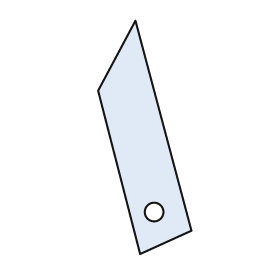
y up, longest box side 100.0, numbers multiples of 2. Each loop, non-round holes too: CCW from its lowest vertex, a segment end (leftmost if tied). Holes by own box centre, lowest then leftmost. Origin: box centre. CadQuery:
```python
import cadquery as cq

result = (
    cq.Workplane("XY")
    .moveTo(-2.0, -50.0)
    .lineTo(20.0, -40.0)
    .lineTo(-4.0, 50.0)
    .lineTo(-20.0, 20.0)
    .close()
    .moveTo(4.0, -32.0)
    .circle(4.0)
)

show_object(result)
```